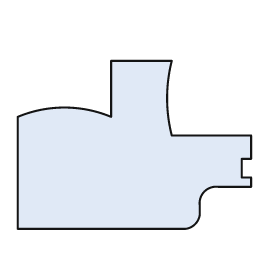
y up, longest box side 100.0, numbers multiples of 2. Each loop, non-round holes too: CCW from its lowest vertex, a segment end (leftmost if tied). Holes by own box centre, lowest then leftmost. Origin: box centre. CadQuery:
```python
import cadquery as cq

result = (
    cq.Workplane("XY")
    .moveTo(-50.0, -36.0)
    .lineTo(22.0, -36.0)
    .threePointArc((26.0, -34.0), (28.0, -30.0))
    .lineTo(28.0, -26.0)
    .threePointArc((30.0, -20.0), (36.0, -18.0))
    .lineTo(50.0, -18.0)
    .lineTo(50.0, -14.0)
    .lineTo(46.0, -14.0)
    .lineTo(46.0, -6.0)
    .lineTo(50.0, -6.0)
    .lineTo(50.0, 4.0)
    .lineTo(16.0, 4.0)
    .threePointArc((14.0, 20.0), (16.0, 36.0))
    .lineTo(-10.0, 36.0)
    .lineTo(-10.0, 12.0)
    .threePointArc((-30.0, 16.0), (-50.0, 12.0))
    .close()
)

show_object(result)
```